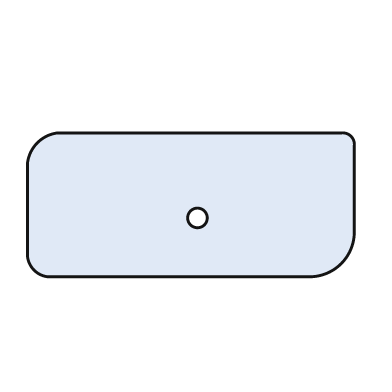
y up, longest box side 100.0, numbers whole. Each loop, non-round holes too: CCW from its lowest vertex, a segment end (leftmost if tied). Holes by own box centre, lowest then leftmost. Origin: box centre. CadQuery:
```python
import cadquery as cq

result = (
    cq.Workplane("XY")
    .moveTo(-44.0, -22.0)
    .lineTo(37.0, -22.0)
    .threePointArc((46.0, -18.0), (50.0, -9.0))
    .lineTo(50.0, 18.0)
    .threePointArc((49.0, 21.0), (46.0, 22.0))
    .lineTo(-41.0, 22.0)
    .threePointArc((-47.0, 19.0), (-50.0, 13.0))
    .lineTo(-50.0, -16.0)
    .threePointArc((-48.0, -20.0), (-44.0, -22.0))
    .close()
    .moveTo(2.0, -4.0)
    .circle(3.0)
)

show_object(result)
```